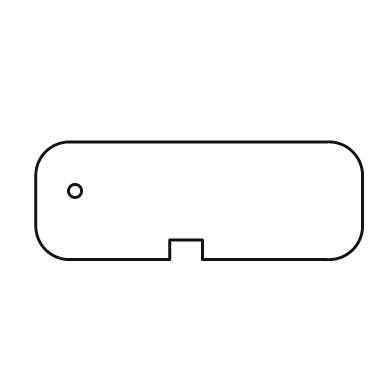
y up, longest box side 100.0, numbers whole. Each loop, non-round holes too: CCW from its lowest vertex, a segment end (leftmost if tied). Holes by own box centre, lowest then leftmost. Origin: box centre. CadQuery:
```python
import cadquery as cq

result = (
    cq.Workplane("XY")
    .moveTo(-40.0, -18.0)
    .lineTo(-9.0, -18.0)
    .lineTo(-9.0, -12.0)
    .lineTo(1.0, -12.0)
    .lineTo(1.0, -18.0)
    .lineTo(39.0, -18.0)
    .threePointArc((47.0, -15.0), (50.0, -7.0))
    .lineTo(50.0, 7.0)
    .threePointArc((47.0, 15.0), (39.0, 18.0))
    .lineTo(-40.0, 18.0)
    .threePointArc((-47.0, 15.0), (-50.0, 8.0))
    .lineTo(-50.0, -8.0)
    .threePointArc((-47.0, -15.0), (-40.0, -18.0))
    .close()
    .moveTo(-38.0, 3.0)
    .circle(2.0)
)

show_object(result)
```